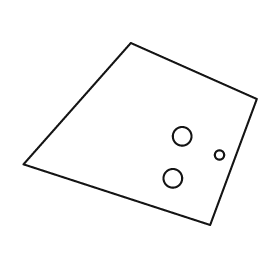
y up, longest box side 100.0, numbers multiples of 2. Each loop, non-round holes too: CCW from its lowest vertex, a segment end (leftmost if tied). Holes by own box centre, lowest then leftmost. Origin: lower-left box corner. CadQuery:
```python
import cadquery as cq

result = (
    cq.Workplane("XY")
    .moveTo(80.0, 0.0)
    .lineTo(100.0, 54.0)
    .lineTo(46.0, 78.0)
    .lineTo(0.0, 26.0)
    .close()
    .moveTo(64.0, 20.0)
    .circle(4.0)
    .moveTo(84.0, 30.0)
    .circle(2.0)
    .moveTo(68.0, 38.0)
    .circle(4.0)
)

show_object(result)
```